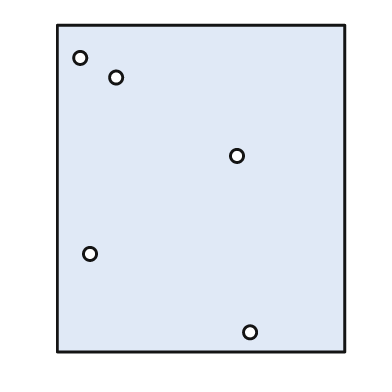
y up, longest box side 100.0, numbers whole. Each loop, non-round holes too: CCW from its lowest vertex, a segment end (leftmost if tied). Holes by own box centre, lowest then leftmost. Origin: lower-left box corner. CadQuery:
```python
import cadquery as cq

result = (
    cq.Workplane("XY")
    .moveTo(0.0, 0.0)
    .lineTo(88.0, 0.0)
    .lineTo(88.0, 100.0)
    .lineTo(0.0, 100.0)
    .close()
    .moveTo(59.0, 6.0)
    .circle(2.0)
    .moveTo(10.0, 30.0)
    .circle(2.0)
    .moveTo(55.0, 60.0)
    .circle(2.0)
    .moveTo(18.0, 84.0)
    .circle(2.0)
    .moveTo(7.0, 90.0)
    .circle(2.0)
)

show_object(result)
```